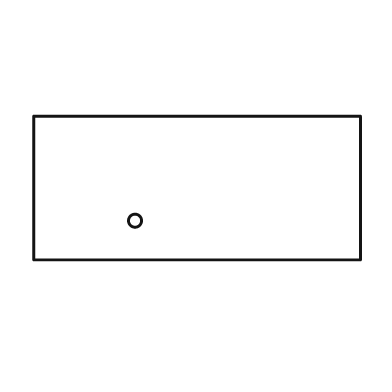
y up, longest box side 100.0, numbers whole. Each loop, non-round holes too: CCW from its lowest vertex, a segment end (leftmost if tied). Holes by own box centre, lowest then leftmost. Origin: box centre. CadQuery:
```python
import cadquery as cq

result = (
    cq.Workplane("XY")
    .moveTo(-50.0, -22.0)
    .lineTo(50.0, -22.0)
    .lineTo(50.0, 22.0)
    .lineTo(-50.0, 22.0)
    .close()
    .moveTo(-19.0, -10.0)
    .circle(2.0)
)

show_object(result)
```